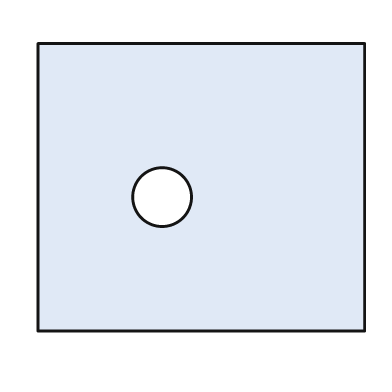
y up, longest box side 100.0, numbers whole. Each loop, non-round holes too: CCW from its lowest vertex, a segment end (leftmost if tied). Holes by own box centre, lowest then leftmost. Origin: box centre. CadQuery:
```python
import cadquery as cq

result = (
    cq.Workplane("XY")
    .moveTo(-50.0, -44.0)
    .lineTo(50.0, -44.0)
    .lineTo(50.0, 44.0)
    .lineTo(-50.0, 44.0)
    .close()
    .moveTo(-12.0, -3.0)
    .circle(9.0)
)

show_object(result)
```